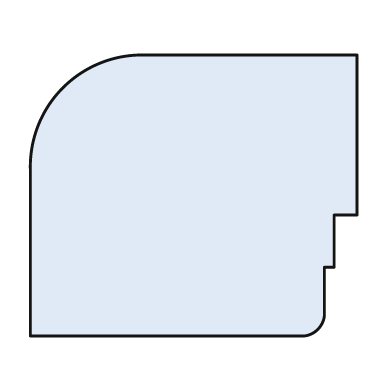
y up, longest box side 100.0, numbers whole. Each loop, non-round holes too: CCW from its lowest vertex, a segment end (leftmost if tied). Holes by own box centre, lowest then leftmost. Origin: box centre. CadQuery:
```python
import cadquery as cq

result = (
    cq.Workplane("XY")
    .moveTo(-50.0, -43.0)
    .lineTo(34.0, -43.0)
    .threePointArc((38.0, -41.0), (40.0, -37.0))
    .lineTo(40.0, -22.0)
    .lineTo(43.0, -22.0)
    .lineTo(43.0, -6.0)
    .lineTo(50.0, -6.0)
    .lineTo(50.0, 43.0)
    .lineTo(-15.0, 43.0)
    .threePointArc((-40.0, 33.0), (-50.0, 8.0))
    .close()
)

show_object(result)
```